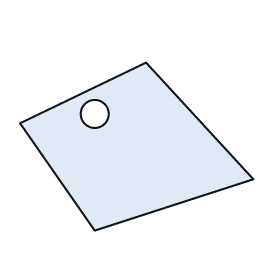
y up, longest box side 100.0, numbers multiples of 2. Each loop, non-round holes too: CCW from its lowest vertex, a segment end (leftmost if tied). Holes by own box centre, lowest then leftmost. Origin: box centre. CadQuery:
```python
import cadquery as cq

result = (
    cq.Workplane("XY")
    .moveTo(-18.0, -36.0)
    .lineTo(50.0, -14.0)
    .lineTo(4.0, 36.0)
    .lineTo(-50.0, 10.0)
    .close()
    .moveTo(-18.0, 14.0)
    .circle(6.0)
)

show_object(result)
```